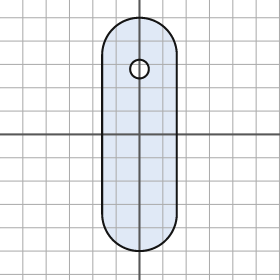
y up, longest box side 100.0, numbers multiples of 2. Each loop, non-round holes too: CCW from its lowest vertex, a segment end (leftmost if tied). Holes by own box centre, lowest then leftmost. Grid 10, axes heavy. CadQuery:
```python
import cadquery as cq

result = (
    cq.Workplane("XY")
    .moveTo(-16.0, -34.0)
    .threePointArc((0.0, -50.0), (16.0, -34.0))
    .lineTo(16.0, 34.0)
    .threePointArc((0.0, 50.0), (-16.0, 34.0))
    .close()
    .moveTo(0.0, 28.0)
    .circle(4.0)
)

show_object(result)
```